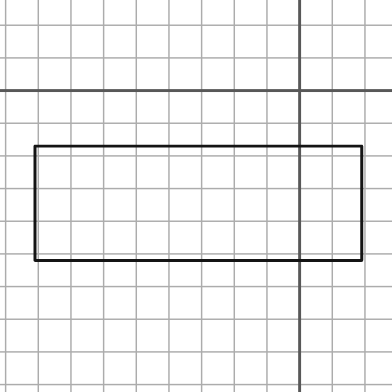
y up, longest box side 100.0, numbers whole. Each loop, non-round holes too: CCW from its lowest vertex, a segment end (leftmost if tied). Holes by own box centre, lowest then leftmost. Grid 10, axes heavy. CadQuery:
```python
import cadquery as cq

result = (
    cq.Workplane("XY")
    .moveTo(-81.0, -52.0)
    .lineTo(19.0, -52.0)
    .lineTo(19.0, -17.0)
    .lineTo(-81.0, -17.0)
    .close()
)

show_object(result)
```